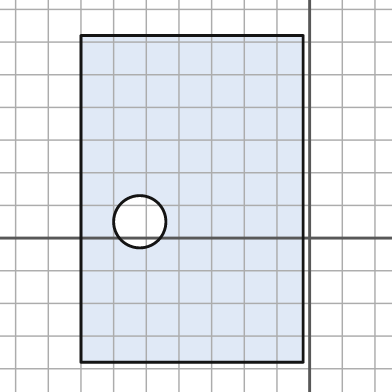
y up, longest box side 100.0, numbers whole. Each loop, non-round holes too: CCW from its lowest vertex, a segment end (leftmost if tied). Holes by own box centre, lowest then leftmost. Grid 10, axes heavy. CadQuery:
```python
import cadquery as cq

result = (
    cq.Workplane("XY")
    .moveTo(-70.0, -38.0)
    .lineTo(-2.0, -38.0)
    .lineTo(-2.0, 62.0)
    .lineTo(-70.0, 62.0)
    .close()
    .moveTo(-52.0, 5.0)
    .circle(8.0)
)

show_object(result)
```